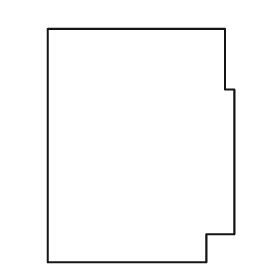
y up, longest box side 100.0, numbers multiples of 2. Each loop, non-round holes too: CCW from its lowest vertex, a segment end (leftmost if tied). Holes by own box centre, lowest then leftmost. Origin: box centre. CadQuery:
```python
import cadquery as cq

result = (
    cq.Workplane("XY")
    .moveTo(-40.0, -50.0)
    .lineTo(28.0, -50.0)
    .lineTo(28.0, -38.0)
    .lineTo(40.0, -38.0)
    .lineTo(40.0, 24.0)
    .lineTo(36.0, 24.0)
    .lineTo(36.0, 50.0)
    .lineTo(-40.0, 50.0)
    .close()
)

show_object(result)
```